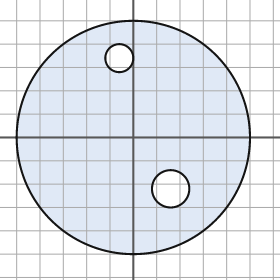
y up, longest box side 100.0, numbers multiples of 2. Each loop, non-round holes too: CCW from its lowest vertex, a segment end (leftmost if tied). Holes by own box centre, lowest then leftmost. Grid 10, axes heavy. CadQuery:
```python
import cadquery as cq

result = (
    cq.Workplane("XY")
    .moveTo(0.0, 0.0)
    .circle(50.0)
    .moveTo(16.0, -22.0)
    .circle(8.0)
    .moveTo(-6.0, 34.0)
    .circle(6.0)
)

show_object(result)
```